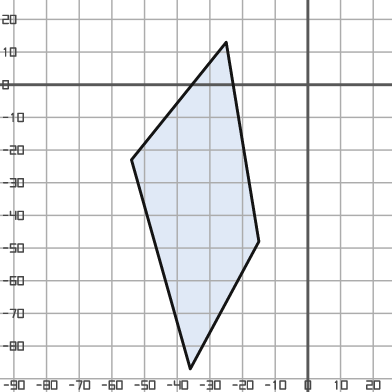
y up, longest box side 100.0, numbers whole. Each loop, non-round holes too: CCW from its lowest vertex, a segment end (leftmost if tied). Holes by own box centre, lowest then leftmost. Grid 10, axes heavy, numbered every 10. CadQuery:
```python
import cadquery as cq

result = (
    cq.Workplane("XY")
    .moveTo(-36.0, -87.0)
    .lineTo(-15.0, -48.0)
    .lineTo(-25.0, 13.0)
    .lineTo(-54.0, -23.0)
    .close()
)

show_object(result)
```